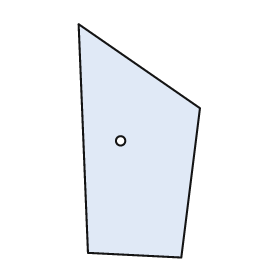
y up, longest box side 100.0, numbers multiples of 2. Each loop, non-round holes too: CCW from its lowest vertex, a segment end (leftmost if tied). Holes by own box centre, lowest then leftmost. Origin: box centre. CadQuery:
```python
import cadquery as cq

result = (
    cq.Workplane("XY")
    .moveTo(18.0, -50.0)
    .lineTo(26.0, 14.0)
    .lineTo(-26.0, 50.0)
    .lineTo(-22.0, -48.0)
    .close()
    .moveTo(-8.0, 0.0)
    .circle(2.0)
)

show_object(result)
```